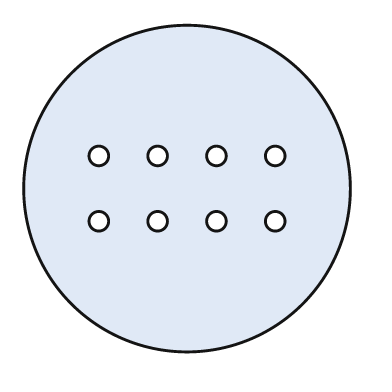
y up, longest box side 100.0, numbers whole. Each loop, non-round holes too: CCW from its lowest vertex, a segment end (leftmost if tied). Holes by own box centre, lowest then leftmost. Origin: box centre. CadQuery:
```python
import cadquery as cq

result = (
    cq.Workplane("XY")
    .moveTo(0.0, 0.0)
    .circle(50.0)
    .moveTo(-27.0, -10.0)
    .circle(3.0)
    .moveTo(-9.0, -10.0)
    .circle(3.0)
    .moveTo(9.0, -10.0)
    .circle(3.0)
    .moveTo(27.0, -10.0)
    .circle(3.0)
    .moveTo(-27.0, 10.0)
    .circle(3.0)
    .moveTo(-9.0, 10.0)
    .circle(3.0)
    .moveTo(9.0, 10.0)
    .circle(3.0)
    .moveTo(27.0, 10.0)
    .circle(3.0)
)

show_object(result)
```